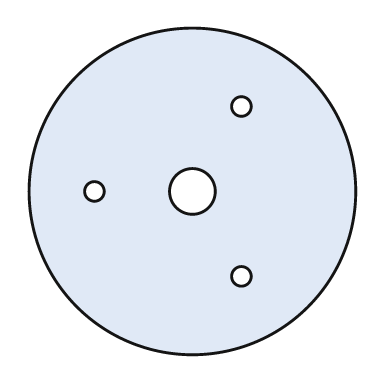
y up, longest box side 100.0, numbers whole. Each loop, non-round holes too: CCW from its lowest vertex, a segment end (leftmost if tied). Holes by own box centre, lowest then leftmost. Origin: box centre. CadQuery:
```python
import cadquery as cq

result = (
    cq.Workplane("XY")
    .moveTo(0.0, 0.0)
    .circle(50.0)
    .moveTo(15.0, -26.0)
    .circle(3.0)
    .moveTo(-30.0, 0.0)
    .circle(3.0)
    .moveTo(0.0, 0.0)
    .circle(7.0)
    .moveTo(15.0, 26.0)
    .circle(3.0)
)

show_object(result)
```